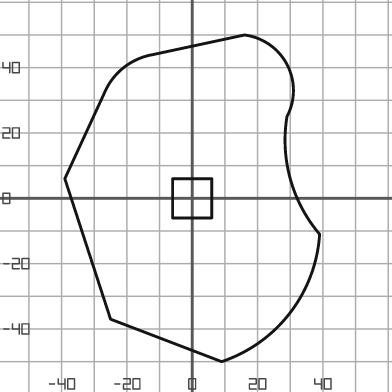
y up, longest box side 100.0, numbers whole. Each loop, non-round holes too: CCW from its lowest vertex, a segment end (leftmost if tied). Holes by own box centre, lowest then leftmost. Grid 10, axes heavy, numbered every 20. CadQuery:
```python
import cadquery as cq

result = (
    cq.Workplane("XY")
    .moveTo(9.0, -50.0)
    .threePointArc((30.0, -35.0), (39.0, -11.0))
    .threePointArc((30.0, 6.0), (29.0, 25.0))
    .threePointArc((29.0, 41.0), (16.0, 50.0))
    .lineTo(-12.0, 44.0)
    .threePointArc((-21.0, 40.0), (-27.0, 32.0))
    .lineTo(-39.0, 6.0)
    .lineTo(-25.0, -37.0)
    .close()
    .moveTo(-6.0, -6.0)
    .lineTo(6.0, -6.0)
    .lineTo(6.0, 6.0)
    .lineTo(-6.0, 6.0)
    .close()
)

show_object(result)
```